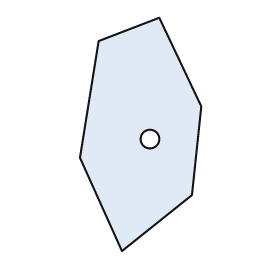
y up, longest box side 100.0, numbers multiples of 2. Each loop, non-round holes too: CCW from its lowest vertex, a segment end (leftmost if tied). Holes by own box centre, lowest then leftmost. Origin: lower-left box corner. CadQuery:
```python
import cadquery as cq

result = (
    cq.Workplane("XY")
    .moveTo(18.0, 0.0)
    .lineTo(48.0, 24.0)
    .lineTo(52.0, 62.0)
    .lineTo(34.0, 100.0)
    .lineTo(8.0, 90.0)
    .lineTo(0.0, 40.0)
    .close()
    .moveTo(30.0, 48.0)
    .circle(4.0)
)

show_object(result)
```